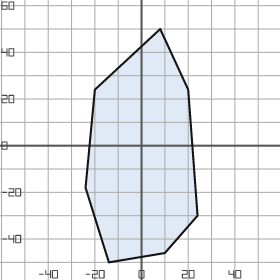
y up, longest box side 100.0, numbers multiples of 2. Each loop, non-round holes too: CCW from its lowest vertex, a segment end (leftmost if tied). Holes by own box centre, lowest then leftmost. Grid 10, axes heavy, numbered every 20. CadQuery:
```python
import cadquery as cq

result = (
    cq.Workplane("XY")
    .moveTo(-14.0, -50.0)
    .lineTo(10.0, -46.0)
    .lineTo(24.0, -30.0)
    .lineTo(20.0, 24.0)
    .lineTo(8.0, 50.0)
    .lineTo(-20.0, 24.0)
    .lineTo(-24.0, -18.0)
    .close()
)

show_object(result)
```